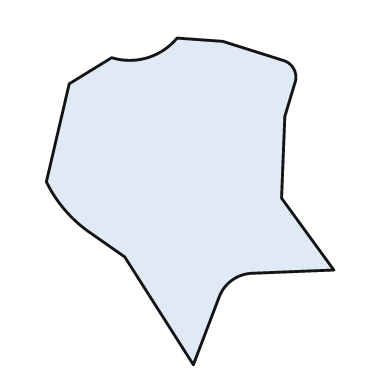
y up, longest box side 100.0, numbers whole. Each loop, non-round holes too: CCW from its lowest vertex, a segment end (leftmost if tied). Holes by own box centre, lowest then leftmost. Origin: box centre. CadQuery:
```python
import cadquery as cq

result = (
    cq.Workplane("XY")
    .moveTo(1.0, -50.0)
    .lineTo(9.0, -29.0)
    .threePointArc((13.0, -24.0), (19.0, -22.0))
    .lineTo(44.0, -21.0)
    .lineTo(28.0, 1.0)
    .lineTo(29.0, 26.0)
    .lineTo(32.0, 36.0)
    .threePointArc((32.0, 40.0), (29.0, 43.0))
    .lineTo(10.0, 49.0)
    .lineTo(-4.0, 50.0)
    .threePointArc((-13.0, 44.0), (-24.0, 44.0))
    .lineTo(-37.0, 36.0)
    .lineTo(-44.0, 6.0)
    .threePointArc((-38.0, -3.0), (-30.0, -10.0))
    .lineTo(-20.0, -17.0)
    .close()
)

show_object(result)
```